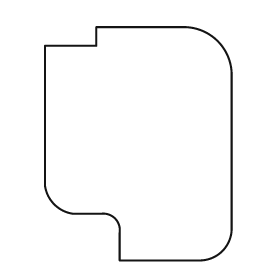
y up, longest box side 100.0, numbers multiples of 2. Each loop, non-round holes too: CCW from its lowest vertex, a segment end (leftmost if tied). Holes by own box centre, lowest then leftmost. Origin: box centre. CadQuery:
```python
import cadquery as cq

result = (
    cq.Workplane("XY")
    .moveTo(-8.0, -50.0)
    .lineTo(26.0, -50.0)
    .threePointArc((36.0, -46.0), (40.0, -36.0))
    .lineTo(40.0, 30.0)
    .threePointArc((34.0, 44.0), (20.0, 50.0))
    .lineTo(-18.0, 50.0)
    .lineTo(-18.0, 42.0)
    .lineTo(-40.0, 42.0)
    .lineTo(-40.0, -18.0)
    .threePointArc((-36.0, -26.0), (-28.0, -30.0))
    .lineTo(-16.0, -30.0)
    .threePointArc((-10.0, -32.0), (-8.0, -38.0))
    .close()
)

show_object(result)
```